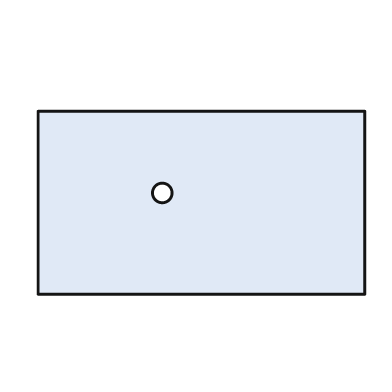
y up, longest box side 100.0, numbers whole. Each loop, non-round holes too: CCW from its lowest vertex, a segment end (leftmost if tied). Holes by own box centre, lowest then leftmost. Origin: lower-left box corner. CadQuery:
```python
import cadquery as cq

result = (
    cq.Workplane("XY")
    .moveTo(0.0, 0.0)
    .lineTo(100.0, 0.0)
    .lineTo(100.0, 56.0)
    .lineTo(0.0, 56.0)
    .close()
    .moveTo(38.0, 31.0)
    .circle(3.0)
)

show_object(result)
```